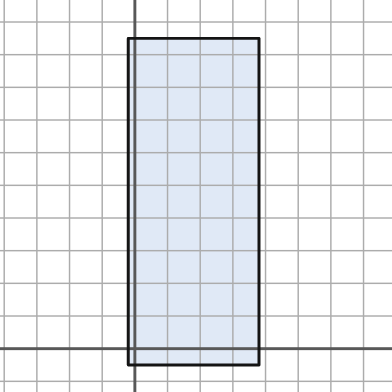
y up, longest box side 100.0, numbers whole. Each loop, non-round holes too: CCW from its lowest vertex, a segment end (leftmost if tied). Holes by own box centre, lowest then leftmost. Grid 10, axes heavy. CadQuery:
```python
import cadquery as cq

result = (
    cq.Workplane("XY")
    .moveTo(-2.0, -5.0)
    .lineTo(38.0, -5.0)
    .lineTo(38.0, 95.0)
    .lineTo(-2.0, 95.0)
    .close()
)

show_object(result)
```